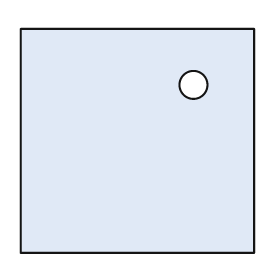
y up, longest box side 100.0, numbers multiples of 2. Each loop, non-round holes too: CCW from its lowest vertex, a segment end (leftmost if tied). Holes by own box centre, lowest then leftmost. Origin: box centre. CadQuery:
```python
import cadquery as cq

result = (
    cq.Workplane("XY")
    .moveTo(-50.0, -48.0)
    .lineTo(50.0, -48.0)
    .lineTo(50.0, 48.0)
    .lineTo(-50.0, 48.0)
    .close()
    .moveTo(24.0, 24.0)
    .circle(6.0)
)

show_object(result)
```